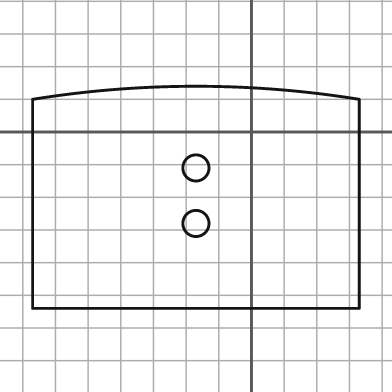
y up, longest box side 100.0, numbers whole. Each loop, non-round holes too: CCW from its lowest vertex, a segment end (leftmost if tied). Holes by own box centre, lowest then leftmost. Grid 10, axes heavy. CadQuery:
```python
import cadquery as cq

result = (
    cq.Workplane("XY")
    .moveTo(-67.0, -54.0)
    .lineTo(33.0, -54.0)
    .lineTo(33.0, 10.0)
    .threePointArc((-17.0, 14.0), (-67.0, 10.0))
    .close()
    .moveTo(-17.0, -28.0)
    .circle(4.0)
    .moveTo(-17.0, -11.0)
    .circle(4.0)
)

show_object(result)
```